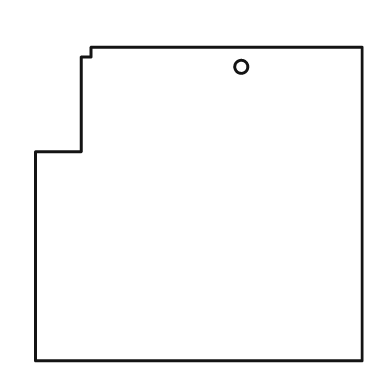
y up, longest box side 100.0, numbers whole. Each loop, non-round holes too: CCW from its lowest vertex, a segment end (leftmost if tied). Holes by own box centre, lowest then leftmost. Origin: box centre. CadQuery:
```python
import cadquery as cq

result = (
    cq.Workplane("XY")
    .moveTo(-50.0, -48.0)
    .lineTo(50.0, -48.0)
    .lineTo(50.0, 48.0)
    .lineTo(-33.0, 48.0)
    .lineTo(-33.0, 45.0)
    .lineTo(-36.0, 45.0)
    .lineTo(-36.0, 16.0)
    .lineTo(-50.0, 16.0)
    .close()
    .moveTo(13.0, 42.0)
    .circle(2.0)
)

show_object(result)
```